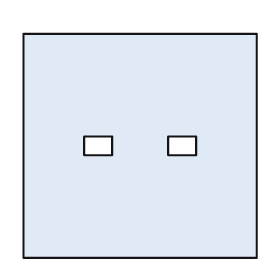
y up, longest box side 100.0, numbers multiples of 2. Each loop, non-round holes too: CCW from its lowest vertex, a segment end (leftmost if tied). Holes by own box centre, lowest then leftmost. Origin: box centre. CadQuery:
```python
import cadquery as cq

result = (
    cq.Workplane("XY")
    .moveTo(-50.0, -48.0)
    .lineTo(50.0, -48.0)
    .lineTo(50.0, 48.0)
    .lineTo(-50.0, 48.0)
    .close()
    .moveTo(-24.0, -4.0)
    .lineTo(-12.0, -4.0)
    .lineTo(-12.0, 4.0)
    .lineTo(-24.0, 4.0)
    .close()
    .moveTo(12.0, -4.0)
    .lineTo(24.0, -4.0)
    .lineTo(24.0, 4.0)
    .lineTo(12.0, 4.0)
    .close()
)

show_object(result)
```